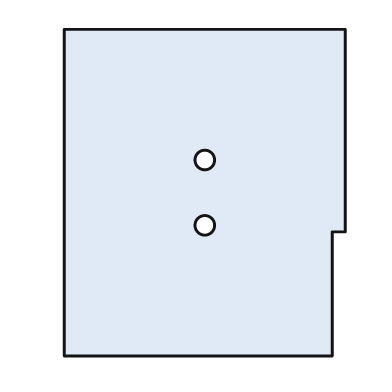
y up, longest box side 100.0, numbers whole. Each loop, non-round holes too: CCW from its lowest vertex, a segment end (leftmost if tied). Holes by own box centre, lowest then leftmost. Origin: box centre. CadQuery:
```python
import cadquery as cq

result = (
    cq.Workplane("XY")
    .moveTo(-43.0, -50.0)
    .lineTo(39.0, -50.0)
    .lineTo(39.0, -12.0)
    .lineTo(43.0, -12.0)
    .lineTo(43.0, 50.0)
    .lineTo(-43.0, 50.0)
    .close()
    .moveTo(0.0, -10.0)
    .circle(3.0)
    .moveTo(0.0, 10.0)
    .circle(3.0)
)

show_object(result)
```